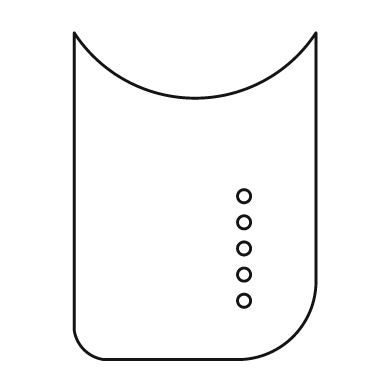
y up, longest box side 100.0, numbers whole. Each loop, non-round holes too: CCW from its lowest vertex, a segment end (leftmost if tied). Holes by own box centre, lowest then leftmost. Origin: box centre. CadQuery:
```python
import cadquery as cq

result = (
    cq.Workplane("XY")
    .moveTo(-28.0, -50.0)
    .lineTo(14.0, -50.0)
    .threePointArc((30.0, -43.0), (37.0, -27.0))
    .lineTo(37.0, 50.0)
    .threePointArc((0.0, 30.0), (-37.0, 50.0))
    .lineTo(-37.0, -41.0)
    .threePointArc((-34.0, -47.0), (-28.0, -50.0))
    .close()
    .moveTo(15.0, -32.0)
    .circle(2.0)
    .moveTo(15.0, -24.0)
    .circle(2.0)
    .moveTo(15.0, -16.0)
    .circle(2.0)
    .moveTo(15.0, -8.0)
    .circle(2.0)
    .moveTo(15.0, 0.0)
    .circle(2.0)
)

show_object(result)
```